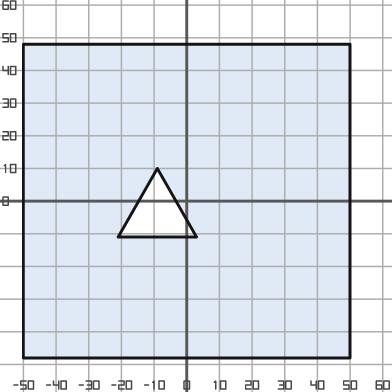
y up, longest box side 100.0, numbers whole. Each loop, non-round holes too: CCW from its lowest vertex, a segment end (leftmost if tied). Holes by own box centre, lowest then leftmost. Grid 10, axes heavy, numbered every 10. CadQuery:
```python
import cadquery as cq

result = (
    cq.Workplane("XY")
    .moveTo(-50.0, -48.0)
    .lineTo(50.0, -48.0)
    .lineTo(50.0, 48.0)
    .lineTo(-50.0, 48.0)
    .close()
    .moveTo(-21.0, -11.0)
    .lineTo(3.0, -11.0)
    .lineTo(-9.0, 10.0)
    .close()
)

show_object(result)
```